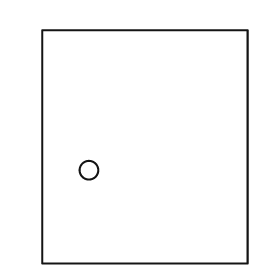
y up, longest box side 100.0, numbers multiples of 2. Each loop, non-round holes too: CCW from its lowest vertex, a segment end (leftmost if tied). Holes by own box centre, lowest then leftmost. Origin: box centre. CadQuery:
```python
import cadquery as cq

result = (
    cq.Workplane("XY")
    .moveTo(-44.0, -50.0)
    .lineTo(44.0, -50.0)
    .lineTo(44.0, 50.0)
    .lineTo(-44.0, 50.0)
    .close()
    .moveTo(-24.0, -10.0)
    .circle(4.0)
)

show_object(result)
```